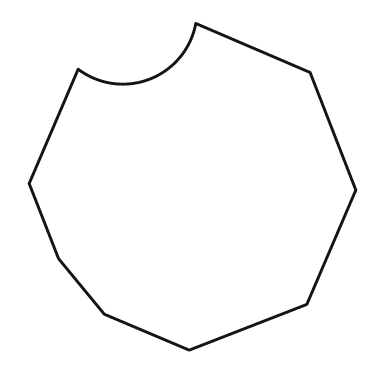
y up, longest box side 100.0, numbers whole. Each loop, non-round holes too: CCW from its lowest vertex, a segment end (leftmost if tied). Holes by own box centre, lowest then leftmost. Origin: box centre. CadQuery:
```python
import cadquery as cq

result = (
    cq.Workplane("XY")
    .moveTo(-1.0, -50.0)
    .lineTo(35.0, -36.0)
    .lineTo(50.0, -1.0)
    .lineTo(36.0, 35.0)
    .lineTo(1.0, 50.0)
    .threePointArc((-13.0, 33.0), (-35.0, 36.0))
    .lineTo(-50.0, 1.0)
    .lineTo(-41.0, -22.0)
    .lineTo(-27.0, -39.0)
    .close()
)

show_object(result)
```